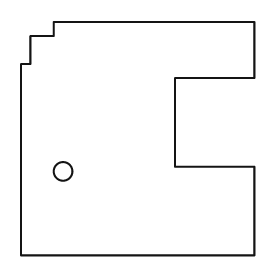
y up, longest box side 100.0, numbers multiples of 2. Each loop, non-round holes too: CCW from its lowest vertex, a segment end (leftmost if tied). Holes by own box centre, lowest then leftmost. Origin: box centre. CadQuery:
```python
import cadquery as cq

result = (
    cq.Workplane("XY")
    .moveTo(-50.0, -50.0)
    .lineTo(50.0, -50.0)
    .lineTo(50.0, -12.0)
    .lineTo(16.0, -12.0)
    .lineTo(16.0, 26.0)
    .lineTo(50.0, 26.0)
    .lineTo(50.0, 50.0)
    .lineTo(-36.0, 50.0)
    .lineTo(-36.0, 44.0)
    .lineTo(-46.0, 44.0)
    .lineTo(-46.0, 32.0)
    .lineTo(-50.0, 32.0)
    .close()
    .moveTo(-32.0, -14.0)
    .circle(4.0)
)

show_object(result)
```